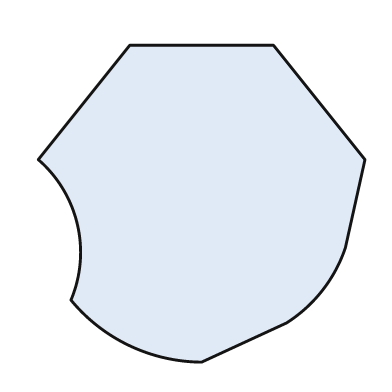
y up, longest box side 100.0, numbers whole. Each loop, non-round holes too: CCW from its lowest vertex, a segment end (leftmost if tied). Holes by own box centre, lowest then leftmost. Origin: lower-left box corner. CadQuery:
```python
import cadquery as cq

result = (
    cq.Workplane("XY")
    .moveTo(50.0, 0.0)
    .lineTo(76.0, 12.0)
    .threePointArc((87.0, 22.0), (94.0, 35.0))
    .lineTo(100.0, 62.0)
    .lineTo(72.0, 97.0)
    .lineTo(28.0, 97.0)
    .lineTo(0.0, 62.0)
    .threePointArc((12.0, 42.0), (10.0, 19.0))
    .threePointArc((28.0, 5.0), (50.0, 0.0))
    .close()
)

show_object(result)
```